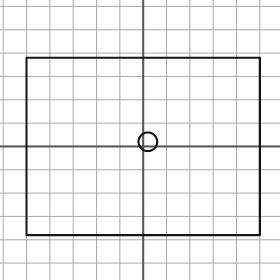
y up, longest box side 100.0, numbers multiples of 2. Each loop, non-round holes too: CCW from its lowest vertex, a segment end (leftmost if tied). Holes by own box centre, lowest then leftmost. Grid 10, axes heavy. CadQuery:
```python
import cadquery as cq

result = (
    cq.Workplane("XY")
    .moveTo(-50.0, -38.0)
    .lineTo(50.0, -38.0)
    .lineTo(50.0, 38.0)
    .lineTo(-50.0, 38.0)
    .close()
    .moveTo(2.0, 2.0)
    .circle(4.0)
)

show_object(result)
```